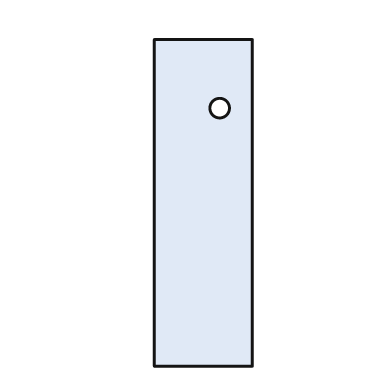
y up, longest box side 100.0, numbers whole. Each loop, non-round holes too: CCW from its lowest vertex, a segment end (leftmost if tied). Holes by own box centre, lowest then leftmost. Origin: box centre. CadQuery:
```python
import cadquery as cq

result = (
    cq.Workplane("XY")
    .moveTo(-15.0, -50.0)
    .lineTo(15.0, -50.0)
    .lineTo(15.0, 50.0)
    .lineTo(-15.0, 50.0)
    .close()
    .moveTo(5.0, 29.0)
    .circle(3.0)
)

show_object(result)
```